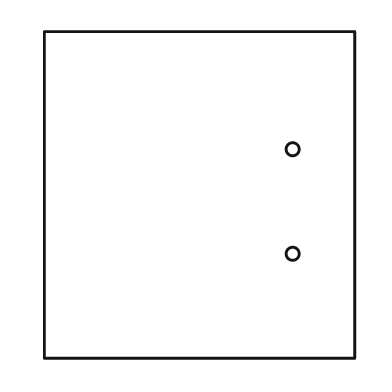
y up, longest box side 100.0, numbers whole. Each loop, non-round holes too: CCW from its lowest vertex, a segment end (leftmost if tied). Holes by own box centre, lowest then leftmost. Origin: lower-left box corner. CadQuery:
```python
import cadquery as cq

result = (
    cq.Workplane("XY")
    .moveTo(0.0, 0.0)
    .lineTo(95.0, 0.0)
    .lineTo(95.0, 100.0)
    .lineTo(0.0, 100.0)
    .close()
    .moveTo(76.0, 32.0)
    .circle(2.0)
    .moveTo(76.0, 64.0)
    .circle(2.0)
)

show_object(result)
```